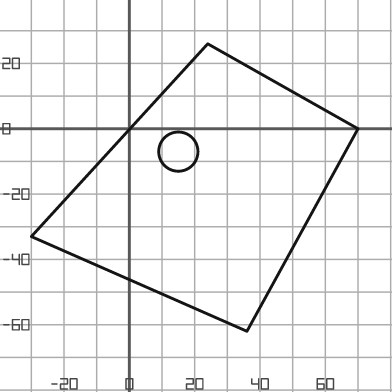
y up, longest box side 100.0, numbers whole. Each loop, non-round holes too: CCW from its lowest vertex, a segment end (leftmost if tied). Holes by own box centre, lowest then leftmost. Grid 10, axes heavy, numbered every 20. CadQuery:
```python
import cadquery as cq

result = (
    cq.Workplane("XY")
    .moveTo(36.0, -62.0)
    .lineTo(70.0, 0.0)
    .lineTo(24.0, 26.0)
    .lineTo(-30.0, -33.0)
    .close()
    .moveTo(15.0, -7.0)
    .circle(6.0)
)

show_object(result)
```